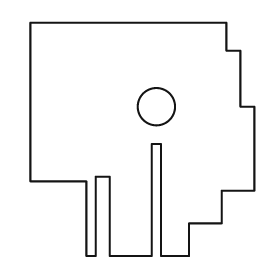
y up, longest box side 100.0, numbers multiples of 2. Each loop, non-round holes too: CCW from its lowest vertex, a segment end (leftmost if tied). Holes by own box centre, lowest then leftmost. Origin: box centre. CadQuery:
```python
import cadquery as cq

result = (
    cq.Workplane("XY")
    .moveTo(-24.0, -50.0)
    .lineTo(-20.0, -50.0)
    .lineTo(-20.0, -16.0)
    .lineTo(-14.0, -16.0)
    .lineTo(-14.0, -50.0)
    .lineTo(4.0, -50.0)
    .lineTo(4.0, -2.0)
    .lineTo(8.0, -2.0)
    .lineTo(8.0, -50.0)
    .lineTo(20.0, -50.0)
    .lineTo(20.0, -36.0)
    .lineTo(34.0, -36.0)
    .lineTo(34.0, -22.0)
    .lineTo(48.0, -22.0)
    .lineTo(48.0, 14.0)
    .lineTo(42.0, 14.0)
    .lineTo(42.0, 38.0)
    .lineTo(36.0, 38.0)
    .lineTo(36.0, 50.0)
    .lineTo(-48.0, 50.0)
    .lineTo(-48.0, -18.0)
    .lineTo(-24.0, -18.0)
    .close()
    .moveTo(6.0, 14.0)
    .circle(8.0)
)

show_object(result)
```